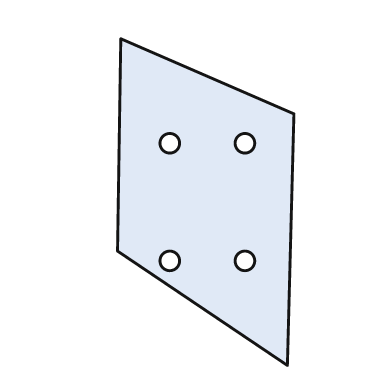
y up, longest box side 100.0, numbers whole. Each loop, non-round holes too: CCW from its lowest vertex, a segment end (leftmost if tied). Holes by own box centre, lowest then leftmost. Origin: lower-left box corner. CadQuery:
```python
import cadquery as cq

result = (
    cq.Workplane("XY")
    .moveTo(52.0, 0.0)
    .lineTo(54.0, 77.0)
    .lineTo(1.0, 100.0)
    .lineTo(0.0, 35.0)
    .close()
    .moveTo(16.0, 32.0)
    .circle(3.0)
    .moveTo(39.0, 32.0)
    .circle(3.0)
    .moveTo(16.0, 68.0)
    .circle(3.0)
    .moveTo(39.0, 68.0)
    .circle(3.0)
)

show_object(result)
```